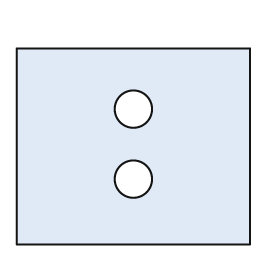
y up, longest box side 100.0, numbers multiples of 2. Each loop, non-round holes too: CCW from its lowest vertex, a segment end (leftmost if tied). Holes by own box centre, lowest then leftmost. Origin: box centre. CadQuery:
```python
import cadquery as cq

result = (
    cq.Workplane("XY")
    .moveTo(-50.0, -42.0)
    .lineTo(50.0, -42.0)
    .lineTo(50.0, 42.0)
    .lineTo(-50.0, 42.0)
    .close()
    .moveTo(0.0, -14.0)
    .circle(8.0)
    .moveTo(0.0, 16.0)
    .circle(8.0)
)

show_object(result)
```